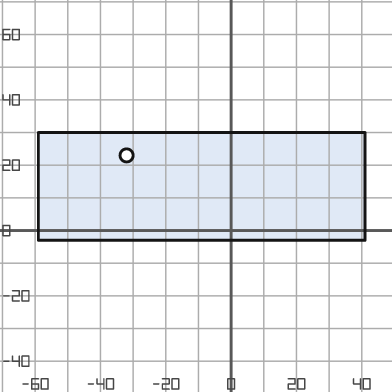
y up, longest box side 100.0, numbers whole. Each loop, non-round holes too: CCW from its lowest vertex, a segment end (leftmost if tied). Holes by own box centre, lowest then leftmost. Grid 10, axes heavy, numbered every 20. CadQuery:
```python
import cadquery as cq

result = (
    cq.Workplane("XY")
    .moveTo(-59.0, -3.0)
    .lineTo(41.0, -3.0)
    .lineTo(41.0, 30.0)
    .lineTo(-59.0, 30.0)
    .close()
    .moveTo(-32.0, 23.0)
    .circle(2.0)
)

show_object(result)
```